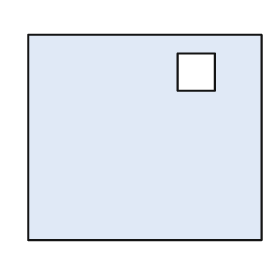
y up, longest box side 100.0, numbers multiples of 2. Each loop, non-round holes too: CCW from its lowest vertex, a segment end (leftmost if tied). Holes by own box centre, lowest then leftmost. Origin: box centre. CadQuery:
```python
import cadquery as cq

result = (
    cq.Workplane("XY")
    .moveTo(-50.0, -44.0)
    .lineTo(50.0, -44.0)
    .lineTo(50.0, 44.0)
    .lineTo(-50.0, 44.0)
    .close()
    .moveTo(14.0, 20.0)
    .lineTo(30.0, 20.0)
    .lineTo(30.0, 36.0)
    .lineTo(14.0, 36.0)
    .close()
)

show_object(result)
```